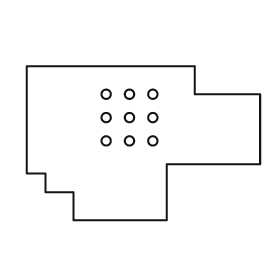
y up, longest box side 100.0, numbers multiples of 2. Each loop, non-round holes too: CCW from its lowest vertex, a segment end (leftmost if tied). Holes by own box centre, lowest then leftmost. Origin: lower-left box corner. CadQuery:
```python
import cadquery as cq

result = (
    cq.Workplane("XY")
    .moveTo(20.0, 0.0)
    .lineTo(60.0, 0.0)
    .lineTo(60.0, 24.0)
    .lineTo(100.0, 24.0)
    .lineTo(100.0, 54.0)
    .lineTo(72.0, 54.0)
    .lineTo(72.0, 66.0)
    .lineTo(0.0, 66.0)
    .lineTo(0.0, 20.0)
    .lineTo(8.0, 20.0)
    .lineTo(8.0, 12.0)
    .lineTo(20.0, 12.0)
    .close()
    .moveTo(34.0, 34.0)
    .circle(2.0)
    .moveTo(44.0, 34.0)
    .circle(2.0)
    .moveTo(54.0, 34.0)
    .circle(2.0)
    .moveTo(34.0, 44.0)
    .circle(2.0)
    .moveTo(44.0, 44.0)
    .circle(2.0)
    .moveTo(54.0, 44.0)
    .circle(2.0)
    .moveTo(34.0, 54.0)
    .circle(2.0)
    .moveTo(44.0, 54.0)
    .circle(2.0)
    .moveTo(54.0, 54.0)
    .circle(2.0)
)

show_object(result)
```